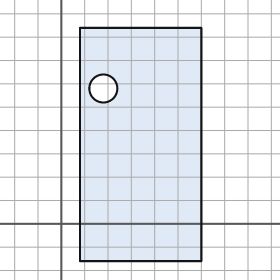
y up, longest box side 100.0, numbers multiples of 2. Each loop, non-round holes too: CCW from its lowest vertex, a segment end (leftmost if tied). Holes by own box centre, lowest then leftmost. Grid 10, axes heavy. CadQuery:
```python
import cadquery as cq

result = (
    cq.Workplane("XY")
    .moveTo(8.0, -16.0)
    .lineTo(60.0, -16.0)
    .lineTo(60.0, 84.0)
    .lineTo(8.0, 84.0)
    .close()
    .moveTo(18.0, 58.0)
    .circle(6.0)
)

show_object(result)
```